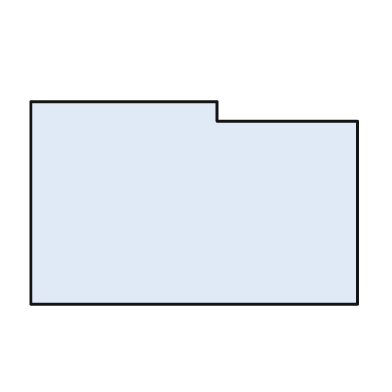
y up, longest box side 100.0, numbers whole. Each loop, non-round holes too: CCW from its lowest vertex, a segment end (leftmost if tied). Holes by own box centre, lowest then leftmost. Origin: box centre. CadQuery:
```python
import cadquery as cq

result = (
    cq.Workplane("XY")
    .moveTo(-50.0, -31.0)
    .lineTo(50.0, -31.0)
    .lineTo(50.0, 25.0)
    .lineTo(7.0, 25.0)
    .lineTo(7.0, 31.0)
    .lineTo(-50.0, 31.0)
    .close()
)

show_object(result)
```